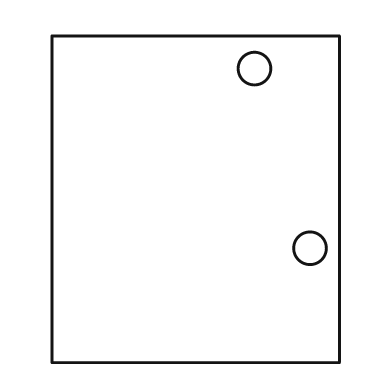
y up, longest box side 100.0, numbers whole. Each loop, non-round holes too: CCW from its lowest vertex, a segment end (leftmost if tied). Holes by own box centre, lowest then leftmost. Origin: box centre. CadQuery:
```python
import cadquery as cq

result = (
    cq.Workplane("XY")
    .moveTo(-44.0, -50.0)
    .lineTo(44.0, -50.0)
    .lineTo(44.0, 50.0)
    .lineTo(-44.0, 50.0)
    .close()
    .moveTo(35.0, -15.0)
    .circle(5.0)
    .moveTo(18.0, 40.0)
    .circle(5.0)
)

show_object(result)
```